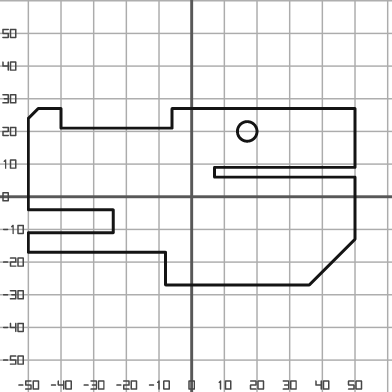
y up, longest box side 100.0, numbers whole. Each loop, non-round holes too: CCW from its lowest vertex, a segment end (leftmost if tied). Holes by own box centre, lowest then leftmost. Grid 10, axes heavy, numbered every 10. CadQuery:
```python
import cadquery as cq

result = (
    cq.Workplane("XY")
    .moveTo(-8.0, -27.0)
    .lineTo(36.0, -27.0)
    .lineTo(50.0, -13.0)
    .lineTo(50.0, 6.0)
    .lineTo(7.0, 6.0)
    .lineTo(7.0, 9.0)
    .lineTo(50.0, 9.0)
    .lineTo(50.0, 27.0)
    .lineTo(-6.0, 27.0)
    .lineTo(-6.0, 21.0)
    .lineTo(-40.0, 21.0)
    .lineTo(-40.0, 27.0)
    .lineTo(-47.0, 27.0)
    .lineTo(-50.0, 24.0)
    .lineTo(-50.0, -4.0)
    .lineTo(-24.0, -4.0)
    .lineTo(-24.0, -11.0)
    .lineTo(-50.0, -11.0)
    .lineTo(-50.0, -17.0)
    .lineTo(-8.0, -17.0)
    .close()
    .moveTo(17.0, 20.0)
    .circle(3.0)
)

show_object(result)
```